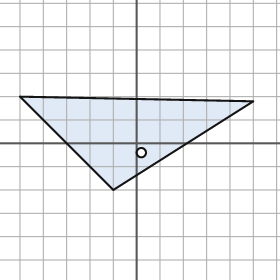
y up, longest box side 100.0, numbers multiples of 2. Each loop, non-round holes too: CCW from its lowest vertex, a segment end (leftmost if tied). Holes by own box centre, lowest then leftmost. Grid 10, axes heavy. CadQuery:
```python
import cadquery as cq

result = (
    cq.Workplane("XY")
    .moveTo(-10.0, -20.0)
    .lineTo(50.0, 18.0)
    .lineTo(-50.0, 20.0)
    .close()
    .moveTo(2.0, -4.0)
    .circle(2.0)
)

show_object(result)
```